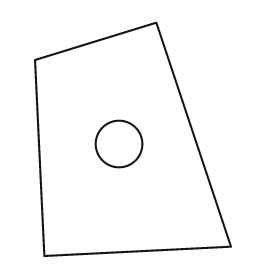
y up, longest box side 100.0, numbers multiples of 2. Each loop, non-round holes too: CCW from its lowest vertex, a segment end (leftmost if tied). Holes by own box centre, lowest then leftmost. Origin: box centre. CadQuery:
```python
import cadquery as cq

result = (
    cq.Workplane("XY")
    .moveTo(-38.0, -50.0)
    .lineTo(42.0, -46.0)
    .lineTo(10.0, 50.0)
    .lineTo(-42.0, 34.0)
    .close()
    .moveTo(-6.0, -2.0)
    .circle(10.0)
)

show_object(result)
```